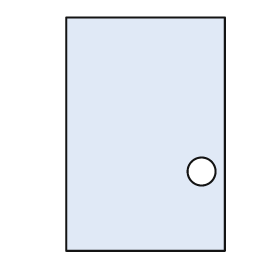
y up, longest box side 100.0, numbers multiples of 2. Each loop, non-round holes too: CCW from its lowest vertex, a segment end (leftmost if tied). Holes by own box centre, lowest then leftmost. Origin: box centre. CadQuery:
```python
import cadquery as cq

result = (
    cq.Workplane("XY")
    .moveTo(-34.0, -50.0)
    .lineTo(34.0, -50.0)
    .lineTo(34.0, 50.0)
    .lineTo(-34.0, 50.0)
    .close()
    .moveTo(24.0, -16.0)
    .circle(6.0)
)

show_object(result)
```